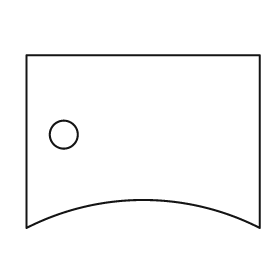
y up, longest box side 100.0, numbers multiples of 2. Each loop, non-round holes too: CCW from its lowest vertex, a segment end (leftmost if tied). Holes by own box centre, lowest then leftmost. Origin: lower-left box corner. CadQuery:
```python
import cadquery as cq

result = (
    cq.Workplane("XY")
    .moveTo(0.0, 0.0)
    .threePointArc((50.0, 12.0), (100.0, 0.0))
    .lineTo(100.0, 74.0)
    .lineTo(0.0, 74.0)
    .close()
    .moveTo(16.0, 40.0)
    .circle(6.0)
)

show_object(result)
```